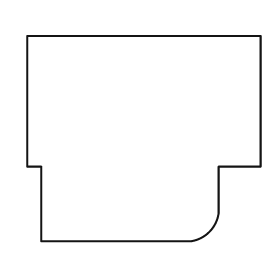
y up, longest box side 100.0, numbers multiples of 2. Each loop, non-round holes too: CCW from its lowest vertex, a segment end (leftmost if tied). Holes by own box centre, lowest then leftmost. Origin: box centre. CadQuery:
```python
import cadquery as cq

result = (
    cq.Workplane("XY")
    .moveTo(-44.0, -44.0)
    .lineTo(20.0, -44.0)
    .threePointArc((28.0, -40.0), (32.0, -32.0))
    .lineTo(32.0, -12.0)
    .lineTo(50.0, -12.0)
    .lineTo(50.0, 44.0)
    .lineTo(-50.0, 44.0)
    .lineTo(-50.0, -12.0)
    .lineTo(-44.0, -12.0)
    .close()
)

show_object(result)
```